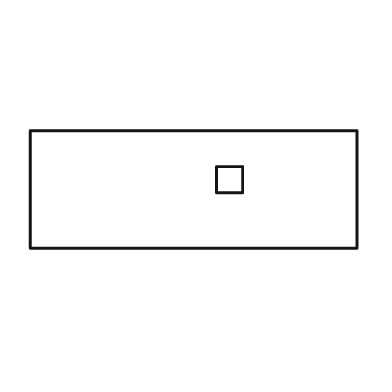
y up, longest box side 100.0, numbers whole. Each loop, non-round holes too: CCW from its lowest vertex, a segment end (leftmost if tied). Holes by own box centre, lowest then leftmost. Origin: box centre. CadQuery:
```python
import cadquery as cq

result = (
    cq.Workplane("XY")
    .moveTo(-50.0, -18.0)
    .lineTo(50.0, -18.0)
    .lineTo(50.0, 18.0)
    .lineTo(-50.0, 18.0)
    .close()
    .moveTo(7.0, -1.0)
    .lineTo(15.0, -1.0)
    .lineTo(15.0, 7.0)
    .lineTo(7.0, 7.0)
    .close()
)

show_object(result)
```